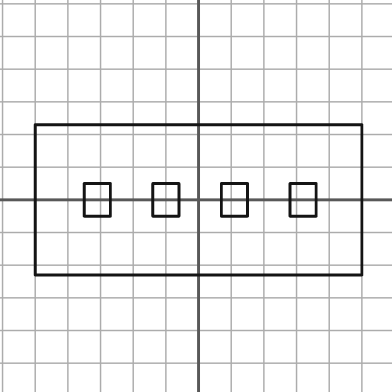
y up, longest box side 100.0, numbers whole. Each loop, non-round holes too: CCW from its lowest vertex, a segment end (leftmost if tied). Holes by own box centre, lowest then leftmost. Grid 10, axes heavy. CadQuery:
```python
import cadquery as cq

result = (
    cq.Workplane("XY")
    .moveTo(-50.0, -23.0)
    .lineTo(50.0, -23.0)
    .lineTo(50.0, 23.0)
    .lineTo(-50.0, 23.0)
    .close()
    .moveTo(-35.0, -5.0)
    .lineTo(-27.0, -5.0)
    .lineTo(-27.0, 5.0)
    .lineTo(-35.0, 5.0)
    .close()
    .moveTo(-14.0, -5.0)
    .lineTo(-6.0, -5.0)
    .lineTo(-6.0, 5.0)
    .lineTo(-14.0, 5.0)
    .close()
    .moveTo(7.0, -5.0)
    .lineTo(15.0, -5.0)
    .lineTo(15.0, 5.0)
    .lineTo(7.0, 5.0)
    .close()
    .moveTo(28.0, -5.0)
    .lineTo(36.0, -5.0)
    .lineTo(36.0, 5.0)
    .lineTo(28.0, 5.0)
    .close()
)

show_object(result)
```